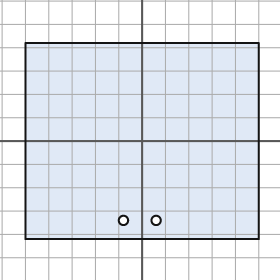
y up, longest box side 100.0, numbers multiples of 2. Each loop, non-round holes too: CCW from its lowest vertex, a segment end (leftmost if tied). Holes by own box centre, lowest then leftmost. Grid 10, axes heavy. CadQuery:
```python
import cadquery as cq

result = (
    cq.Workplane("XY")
    .moveTo(-50.0, -42.0)
    .lineTo(50.0, -42.0)
    .lineTo(50.0, 42.0)
    .lineTo(-50.0, 42.0)
    .close()
    .moveTo(-8.0, -34.0)
    .circle(2.0)
    .moveTo(6.0, -34.0)
    .circle(2.0)
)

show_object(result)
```